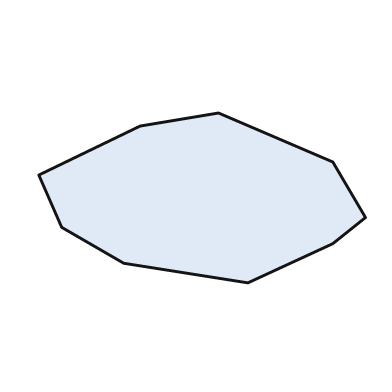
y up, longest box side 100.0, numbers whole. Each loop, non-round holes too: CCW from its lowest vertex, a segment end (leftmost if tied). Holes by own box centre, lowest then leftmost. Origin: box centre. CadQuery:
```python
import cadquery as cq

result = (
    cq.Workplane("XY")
    .moveTo(14.0, -26.0)
    .lineTo(40.0, -14.0)
    .lineTo(50.0, -6.0)
    .lineTo(40.0, 11.0)
    .lineTo(5.0, 26.0)
    .lineTo(-19.0, 22.0)
    .lineTo(-50.0, 7.0)
    .lineTo(-43.0, -9.0)
    .lineTo(-24.0, -20.0)
    .close()
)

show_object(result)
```